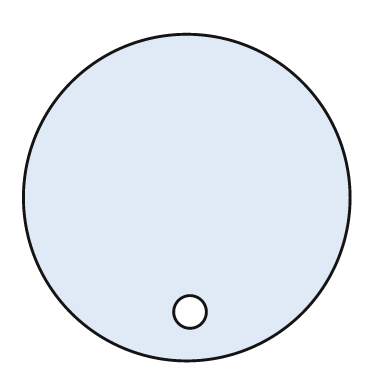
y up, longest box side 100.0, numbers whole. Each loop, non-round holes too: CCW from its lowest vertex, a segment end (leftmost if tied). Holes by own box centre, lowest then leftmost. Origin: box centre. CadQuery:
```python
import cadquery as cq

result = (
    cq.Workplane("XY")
    .moveTo(0.0, 0.0)
    .circle(50.0)
    .moveTo(1.0, -35.0)
    .circle(5.0)
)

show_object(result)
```